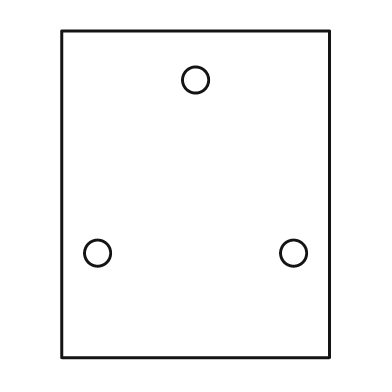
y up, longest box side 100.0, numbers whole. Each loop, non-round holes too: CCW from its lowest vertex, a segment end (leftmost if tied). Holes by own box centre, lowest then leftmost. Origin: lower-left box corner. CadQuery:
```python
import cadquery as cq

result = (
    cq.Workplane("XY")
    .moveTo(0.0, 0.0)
    .lineTo(82.0, 0.0)
    .lineTo(82.0, 100.0)
    .lineTo(0.0, 100.0)
    .close()
    .moveTo(11.0, 32.0)
    .circle(4.0)
    .moveTo(71.0, 32.0)
    .circle(4.0)
    .moveTo(41.0, 85.0)
    .circle(4.0)
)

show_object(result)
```